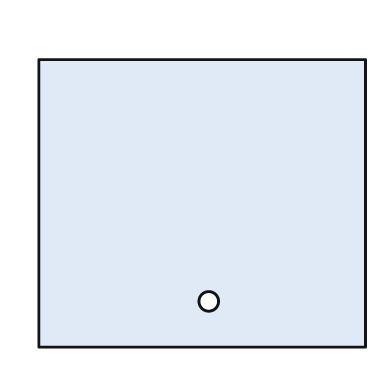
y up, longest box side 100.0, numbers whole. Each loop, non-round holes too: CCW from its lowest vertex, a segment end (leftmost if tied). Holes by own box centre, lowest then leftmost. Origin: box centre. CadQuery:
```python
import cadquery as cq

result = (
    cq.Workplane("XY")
    .moveTo(-50.0, -44.0)
    .lineTo(50.0, -44.0)
    .lineTo(50.0, 44.0)
    .lineTo(-50.0, 44.0)
    .close()
    .moveTo(2.0, -30.0)
    .circle(3.0)
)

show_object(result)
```